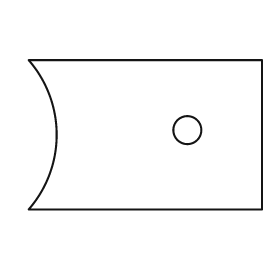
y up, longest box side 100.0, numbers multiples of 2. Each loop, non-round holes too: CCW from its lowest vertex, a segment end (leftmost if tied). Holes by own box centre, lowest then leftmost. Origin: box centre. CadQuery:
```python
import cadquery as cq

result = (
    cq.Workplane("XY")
    .moveTo(-50.0, -32.0)
    .lineTo(50.0, -32.0)
    .lineTo(50.0, 32.0)
    .lineTo(-50.0, 32.0)
    .threePointArc((-38.0, 0.0), (-50.0, -32.0))
    .close()
    .moveTo(18.0, 2.0)
    .circle(6.0)
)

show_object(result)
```